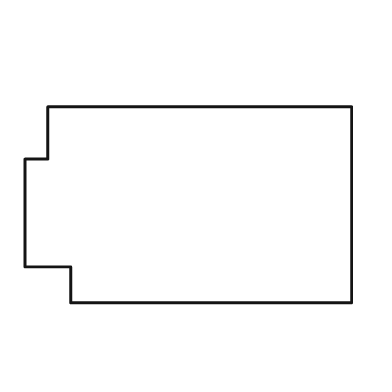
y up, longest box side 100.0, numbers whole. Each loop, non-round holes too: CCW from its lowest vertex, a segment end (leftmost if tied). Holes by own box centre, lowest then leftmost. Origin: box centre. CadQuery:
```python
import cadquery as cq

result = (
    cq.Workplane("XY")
    .moveTo(-36.0, -30.0)
    .lineTo(50.0, -30.0)
    .lineTo(50.0, 30.0)
    .lineTo(-43.0, 30.0)
    .lineTo(-43.0, 14.0)
    .lineTo(-50.0, 14.0)
    .lineTo(-50.0, -19.0)
    .lineTo(-36.0, -19.0)
    .close()
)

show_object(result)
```